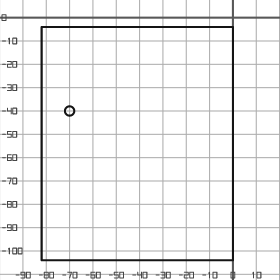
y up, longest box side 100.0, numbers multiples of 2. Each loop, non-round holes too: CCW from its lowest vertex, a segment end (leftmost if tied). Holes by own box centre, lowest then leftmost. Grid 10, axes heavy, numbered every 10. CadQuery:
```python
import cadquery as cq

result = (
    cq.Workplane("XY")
    .moveTo(-82.0, -104.0)
    .lineTo(0.0, -104.0)
    .lineTo(0.0, -4.0)
    .lineTo(-82.0, -4.0)
    .close()
    .moveTo(-70.0, -40.0)
    .circle(2.0)
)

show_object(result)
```